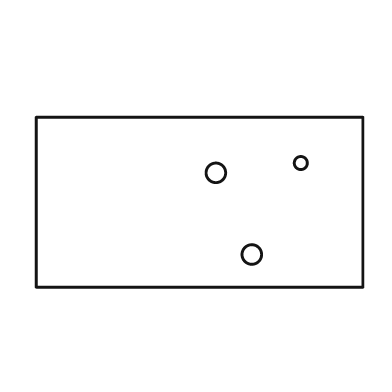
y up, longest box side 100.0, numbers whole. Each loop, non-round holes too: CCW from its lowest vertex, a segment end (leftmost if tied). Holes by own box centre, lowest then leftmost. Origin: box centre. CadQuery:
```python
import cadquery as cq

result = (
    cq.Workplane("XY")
    .moveTo(-50.0, -26.0)
    .lineTo(50.0, -26.0)
    .lineTo(50.0, 26.0)
    .lineTo(-50.0, 26.0)
    .close()
    .moveTo(16.0, -16.0)
    .circle(3.0)
    .moveTo(5.0, 9.0)
    .circle(3.0)
    .moveTo(31.0, 12.0)
    .circle(2.0)
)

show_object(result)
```